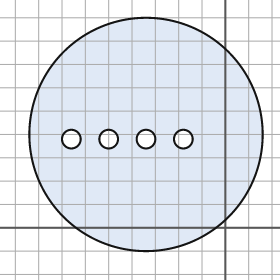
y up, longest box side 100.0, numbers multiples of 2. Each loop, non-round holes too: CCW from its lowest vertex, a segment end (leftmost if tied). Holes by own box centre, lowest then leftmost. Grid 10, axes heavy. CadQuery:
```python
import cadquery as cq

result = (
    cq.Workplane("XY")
    .moveTo(-34.0, 40.0)
    .circle(50.0)
    .moveTo(-66.0, 38.0)
    .circle(4.0)
    .moveTo(-50.0, 38.0)
    .circle(4.0)
    .moveTo(-34.0, 38.0)
    .circle(4.0)
    .moveTo(-18.0, 38.0)
    .circle(4.0)
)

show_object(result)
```